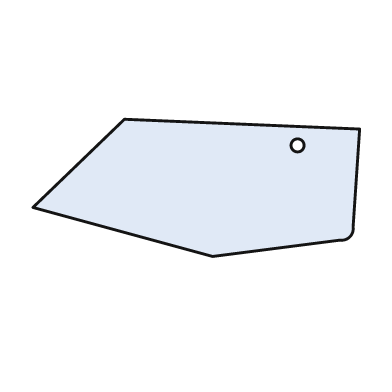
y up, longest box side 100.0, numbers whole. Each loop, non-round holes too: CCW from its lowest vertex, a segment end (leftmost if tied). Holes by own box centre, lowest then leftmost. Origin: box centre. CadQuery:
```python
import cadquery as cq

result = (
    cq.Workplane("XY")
    .moveTo(5.0, -21.0)
    .lineTo(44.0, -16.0)
    .threePointArc((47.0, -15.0), (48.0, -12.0))
    .lineTo(50.0, 18.0)
    .lineTo(-22.0, 21.0)
    .lineTo(-50.0, -6.0)
    .close()
    .moveTo(31.0, 13.0)
    .circle(2.0)
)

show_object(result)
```